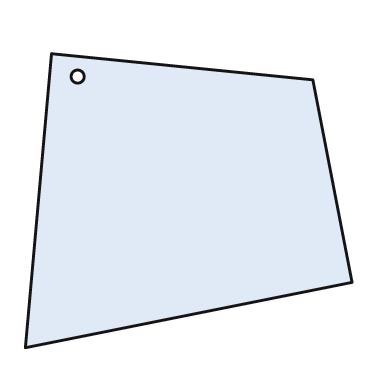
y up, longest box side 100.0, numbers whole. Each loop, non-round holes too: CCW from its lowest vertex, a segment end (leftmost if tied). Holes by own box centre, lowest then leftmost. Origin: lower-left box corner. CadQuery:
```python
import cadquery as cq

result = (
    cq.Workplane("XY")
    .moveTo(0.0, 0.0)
    .lineTo(100.0, 20.0)
    .lineTo(88.0, 82.0)
    .lineTo(8.0, 90.0)
    .close()
    .moveTo(16.0, 83.0)
    .circle(2.0)
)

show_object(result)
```